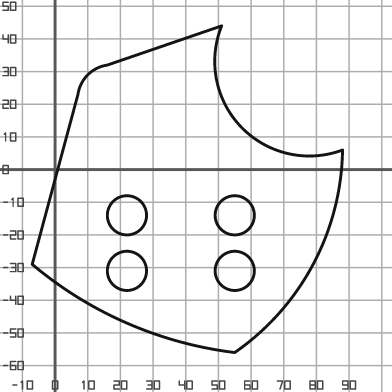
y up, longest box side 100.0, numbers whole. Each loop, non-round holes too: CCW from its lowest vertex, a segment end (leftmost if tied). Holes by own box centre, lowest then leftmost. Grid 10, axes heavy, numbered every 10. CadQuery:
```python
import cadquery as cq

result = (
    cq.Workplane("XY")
    .moveTo(55.0, -56.0)
    .threePointArc((79.0, -29.0), (88.0, 6.0))
    .threePointArc((57.0, 13.0), (51.0, 44.0))
    .lineTo(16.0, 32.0)
    .threePointArc((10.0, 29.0), (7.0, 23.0))
    .lineTo(-7.0, -29.0)
    .threePointArc((22.0, -47.0), (55.0, -56.0))
    .close()
    .moveTo(22.0, -31.0)
    .circle(6.0)
    .moveTo(55.0, -31.0)
    .circle(6.0)
    .moveTo(22.0, -14.0)
    .circle(6.0)
    .moveTo(55.0, -14.0)
    .circle(6.0)
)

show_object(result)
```